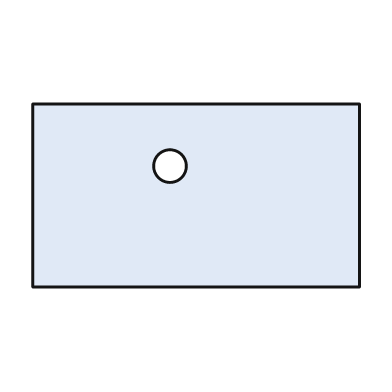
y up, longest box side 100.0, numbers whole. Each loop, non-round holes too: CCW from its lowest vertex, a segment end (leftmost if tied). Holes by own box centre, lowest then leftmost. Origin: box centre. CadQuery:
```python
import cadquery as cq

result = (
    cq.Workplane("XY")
    .moveTo(-50.0, -28.0)
    .lineTo(50.0, -28.0)
    .lineTo(50.0, 28.0)
    .lineTo(-50.0, 28.0)
    .close()
    .moveTo(-8.0, 9.0)
    .circle(5.0)
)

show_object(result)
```